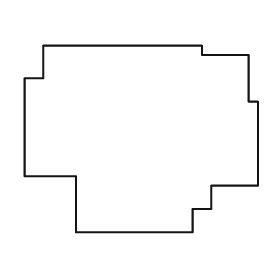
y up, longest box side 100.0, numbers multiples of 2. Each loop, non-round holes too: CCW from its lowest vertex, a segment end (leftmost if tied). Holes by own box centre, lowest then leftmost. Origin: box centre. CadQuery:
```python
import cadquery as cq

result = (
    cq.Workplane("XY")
    .moveTo(-28.0, -40.0)
    .lineTo(22.0, -40.0)
    .lineTo(22.0, -30.0)
    .lineTo(30.0, -30.0)
    .lineTo(30.0, -20.0)
    .lineTo(50.0, -20.0)
    .lineTo(50.0, 16.0)
    .lineTo(46.0, 16.0)
    .lineTo(46.0, 36.0)
    .lineTo(26.0, 36.0)
    .lineTo(26.0, 40.0)
    .lineTo(-42.0, 40.0)
    .lineTo(-42.0, 26.0)
    .lineTo(-50.0, 26.0)
    .lineTo(-50.0, -16.0)
    .lineTo(-28.0, -16.0)
    .close()
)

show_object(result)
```